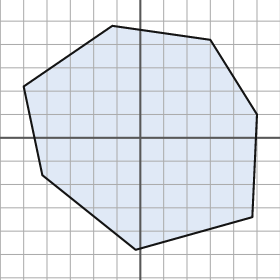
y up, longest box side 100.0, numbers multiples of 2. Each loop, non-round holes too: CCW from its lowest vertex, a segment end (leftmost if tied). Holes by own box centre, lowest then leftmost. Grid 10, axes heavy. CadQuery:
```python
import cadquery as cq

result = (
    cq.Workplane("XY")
    .moveTo(-2.0, -48.0)
    .lineTo(48.0, -34.0)
    .lineTo(50.0, 10.0)
    .lineTo(30.0, 42.0)
    .lineTo(-12.0, 48.0)
    .lineTo(-50.0, 22.0)
    .lineTo(-42.0, -16.0)
    .close()
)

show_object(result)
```